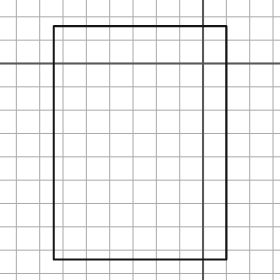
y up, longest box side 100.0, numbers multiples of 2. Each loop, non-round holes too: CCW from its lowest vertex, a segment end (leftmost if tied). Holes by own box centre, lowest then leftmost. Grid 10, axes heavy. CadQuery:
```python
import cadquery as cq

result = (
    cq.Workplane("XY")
    .moveTo(-64.0, -84.0)
    .lineTo(10.0, -84.0)
    .lineTo(10.0, 16.0)
    .lineTo(-64.0, 16.0)
    .close()
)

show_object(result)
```